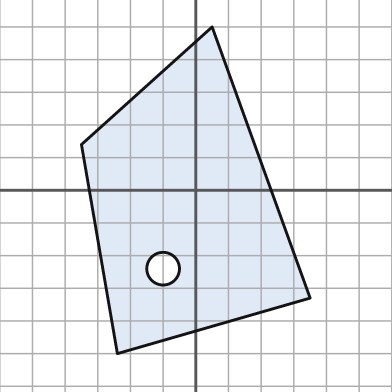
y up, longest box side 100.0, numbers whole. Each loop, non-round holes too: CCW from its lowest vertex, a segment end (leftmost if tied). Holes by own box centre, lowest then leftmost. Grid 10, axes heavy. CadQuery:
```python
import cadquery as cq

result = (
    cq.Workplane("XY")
    .moveTo(-24.0, -50.0)
    .lineTo(35.0, -33.0)
    .lineTo(5.0, 50.0)
    .lineTo(-35.0, 14.0)
    .close()
    .moveTo(-10.0, -24.0)
    .circle(5.0)
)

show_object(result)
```